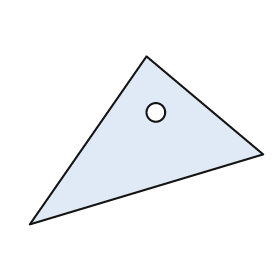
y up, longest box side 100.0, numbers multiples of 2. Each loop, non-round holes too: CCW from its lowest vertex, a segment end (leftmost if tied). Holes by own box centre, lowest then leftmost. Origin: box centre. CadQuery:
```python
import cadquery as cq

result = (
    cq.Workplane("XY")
    .moveTo(-50.0, -36.0)
    .lineTo(50.0, -6.0)
    .lineTo(0.0, 36.0)
    .close()
    .moveTo(4.0, 12.0)
    .circle(4.0)
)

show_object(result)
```